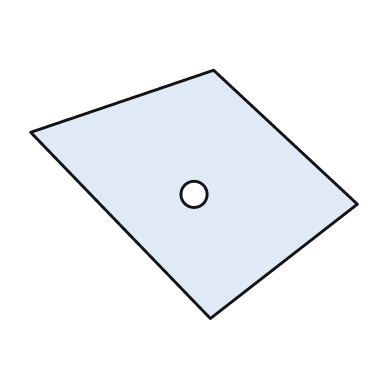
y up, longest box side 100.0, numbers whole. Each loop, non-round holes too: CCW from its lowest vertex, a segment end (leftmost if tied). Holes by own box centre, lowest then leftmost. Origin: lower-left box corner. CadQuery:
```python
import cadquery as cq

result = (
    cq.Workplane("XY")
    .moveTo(55.0, 0.0)
    .lineTo(100.0, 35.0)
    .lineTo(56.0, 76.0)
    .lineTo(0.0, 57.0)
    .close()
    .moveTo(50.0, 38.0)
    .circle(4.0)
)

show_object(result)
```